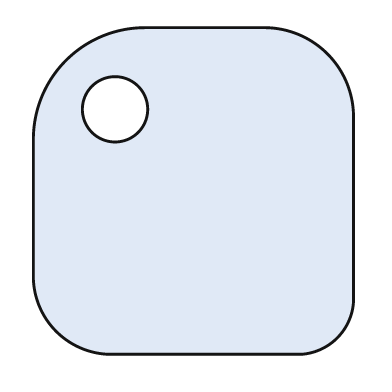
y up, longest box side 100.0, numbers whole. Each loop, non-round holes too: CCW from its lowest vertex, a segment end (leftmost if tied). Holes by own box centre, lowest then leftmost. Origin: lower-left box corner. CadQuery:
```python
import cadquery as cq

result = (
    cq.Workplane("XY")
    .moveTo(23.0, 0.0)
    .lineTo(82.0, 0.0)
    .threePointArc((93.0, 5.0), (98.0, 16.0))
    .lineTo(98.0, 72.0)
    .threePointArc((90.0, 92.0), (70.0, 100.0))
    .lineTo(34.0, 100.0)
    .threePointArc((10.0, 90.0), (0.0, 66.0))
    .lineTo(0.0, 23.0)
    .threePointArc((7.0, 7.0), (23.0, 0.0))
    .close()
    .moveTo(25.0, 75.0)
    .circle(10.0)
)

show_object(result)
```